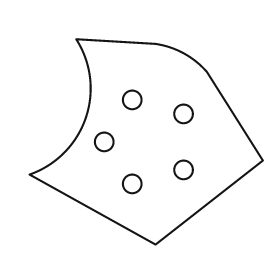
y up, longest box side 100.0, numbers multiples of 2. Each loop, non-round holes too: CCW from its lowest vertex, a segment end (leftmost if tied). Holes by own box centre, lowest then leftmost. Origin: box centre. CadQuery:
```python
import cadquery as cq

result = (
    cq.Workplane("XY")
    .moveTo(4.0, -44.0)
    .lineTo(50.0, -8.0)
    .lineTo(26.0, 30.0)
    .threePointArc((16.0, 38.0), (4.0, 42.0))
    .lineTo(-30.0, 44.0)
    .threePointArc((-26.0, 10.0), (-50.0, -14.0))
    .close()
    .moveTo(-6.0, -18.0)
    .circle(4.0)
    .moveTo(16.0, -12.0)
    .circle(4.0)
    .moveTo(-18.0, 0.0)
    .circle(4.0)
    .moveTo(16.0, 12.0)
    .circle(4.0)
    .moveTo(-6.0, 18.0)
    .circle(4.0)
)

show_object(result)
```